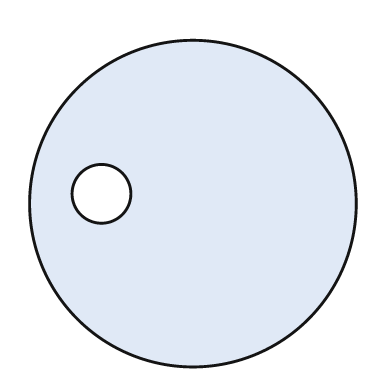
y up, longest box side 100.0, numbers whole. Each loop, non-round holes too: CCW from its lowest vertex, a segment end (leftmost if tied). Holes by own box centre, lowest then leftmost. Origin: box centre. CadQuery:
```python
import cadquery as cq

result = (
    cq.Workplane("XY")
    .moveTo(0.0, 0.0)
    .circle(50.0)
    .moveTo(-28.0, 3.0)
    .circle(9.0)
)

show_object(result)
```